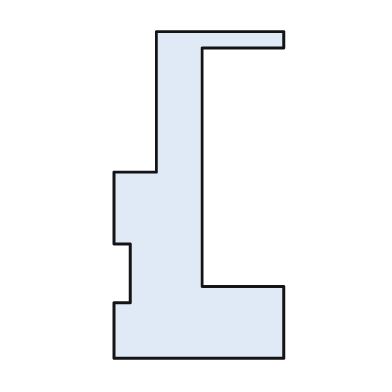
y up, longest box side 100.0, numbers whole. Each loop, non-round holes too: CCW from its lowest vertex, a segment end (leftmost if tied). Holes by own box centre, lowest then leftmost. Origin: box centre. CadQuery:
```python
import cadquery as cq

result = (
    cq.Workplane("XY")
    .moveTo(-26.0, -50.0)
    .lineTo(26.0, -50.0)
    .lineTo(26.0, -28.0)
    .lineTo(1.0, -28.0)
    .lineTo(1.0, 45.0)
    .lineTo(26.0, 45.0)
    .lineTo(26.0, 50.0)
    .lineTo(-13.0, 50.0)
    .lineTo(-13.0, 7.0)
    .lineTo(-26.0, 7.0)
    .lineTo(-26.0, -15.0)
    .lineTo(-21.0, -15.0)
    .lineTo(-21.0, -33.0)
    .lineTo(-26.0, -33.0)
    .close()
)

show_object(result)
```